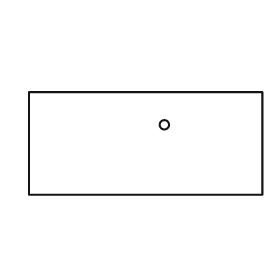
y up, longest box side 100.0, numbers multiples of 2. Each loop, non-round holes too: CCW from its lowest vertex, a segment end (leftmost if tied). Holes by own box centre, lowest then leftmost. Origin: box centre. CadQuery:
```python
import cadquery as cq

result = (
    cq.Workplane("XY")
    .moveTo(-50.0, -22.0)
    .lineTo(50.0, -22.0)
    .lineTo(50.0, 22.0)
    .lineTo(-50.0, 22.0)
    .close()
    .moveTo(8.0, 8.0)
    .circle(2.0)
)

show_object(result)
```